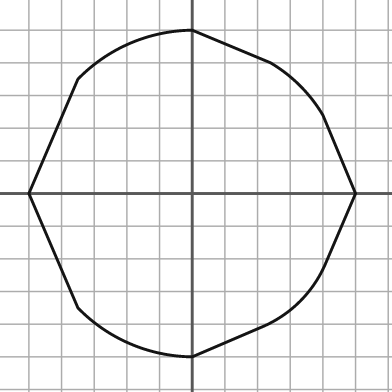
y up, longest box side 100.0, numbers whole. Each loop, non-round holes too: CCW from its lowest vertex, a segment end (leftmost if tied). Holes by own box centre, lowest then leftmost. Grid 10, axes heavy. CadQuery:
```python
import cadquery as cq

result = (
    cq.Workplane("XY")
    .moveTo(0.0, -50.0)
    .lineTo(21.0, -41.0)
    .threePointArc((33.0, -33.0), (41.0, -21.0))
    .lineTo(50.0, 0.0)
    .lineTo(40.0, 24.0)
    .threePointArc((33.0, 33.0), (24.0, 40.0))
    .lineTo(0.0, 50.0)
    .threePointArc((-19.0, 46.0), (-35.0, 35.0))
    .lineTo(-50.0, 0.0)
    .lineTo(-35.0, -35.0)
    .threePointArc((-19.0, -46.0), (0.0, -50.0))
    .close()
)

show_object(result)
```